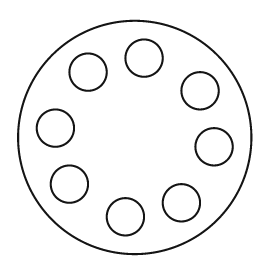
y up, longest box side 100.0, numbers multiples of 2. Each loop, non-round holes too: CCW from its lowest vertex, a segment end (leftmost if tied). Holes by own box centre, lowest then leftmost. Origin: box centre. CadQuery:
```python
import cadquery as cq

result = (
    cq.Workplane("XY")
    .moveTo(0.0, 0.0)
    .circle(50.0)
    .moveTo(-4.0, -34.0)
    .circle(8.0)
    .moveTo(20.0, -28.0)
    .circle(8.0)
    .moveTo(-28.0, -20.0)
    .circle(8.0)
    .moveTo(34.0, -4.0)
    .circle(8.0)
    .moveTo(-34.0, 4.0)
    .circle(8.0)
    .moveTo(28.0, 20.0)
    .circle(8.0)
    .moveTo(-20.0, 28.0)
    .circle(8.0)
    .moveTo(4.0, 34.0)
    .circle(8.0)
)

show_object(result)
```